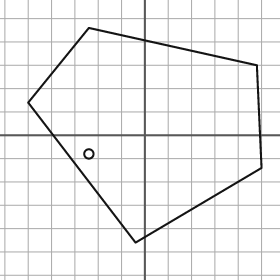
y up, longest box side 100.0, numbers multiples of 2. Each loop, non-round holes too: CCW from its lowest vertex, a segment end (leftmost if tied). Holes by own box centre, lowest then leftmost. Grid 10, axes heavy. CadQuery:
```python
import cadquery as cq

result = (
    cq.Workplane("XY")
    .moveTo(-4.0, -46.0)
    .lineTo(50.0, -14.0)
    .lineTo(48.0, 30.0)
    .lineTo(-24.0, 46.0)
    .lineTo(-50.0, 14.0)
    .close()
    .moveTo(-24.0, -8.0)
    .circle(2.0)
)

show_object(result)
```